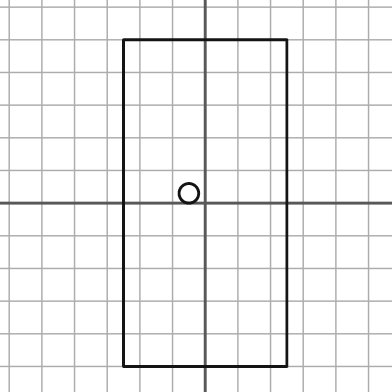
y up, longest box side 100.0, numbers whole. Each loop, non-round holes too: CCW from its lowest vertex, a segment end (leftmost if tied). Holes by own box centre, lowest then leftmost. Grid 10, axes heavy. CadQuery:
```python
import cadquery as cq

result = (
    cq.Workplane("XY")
    .moveTo(-25.0, -50.0)
    .lineTo(25.0, -50.0)
    .lineTo(25.0, 50.0)
    .lineTo(-25.0, 50.0)
    .close()
    .moveTo(-5.0, 3.0)
    .circle(3.0)
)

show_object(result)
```